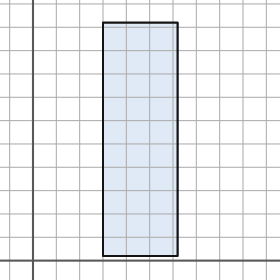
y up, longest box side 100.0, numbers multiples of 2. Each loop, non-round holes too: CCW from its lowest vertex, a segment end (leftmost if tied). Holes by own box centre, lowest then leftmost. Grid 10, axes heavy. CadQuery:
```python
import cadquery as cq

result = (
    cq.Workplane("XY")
    .moveTo(30.0, 2.0)
    .lineTo(62.0, 2.0)
    .lineTo(62.0, 102.0)
    .lineTo(30.0, 102.0)
    .close()
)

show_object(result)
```